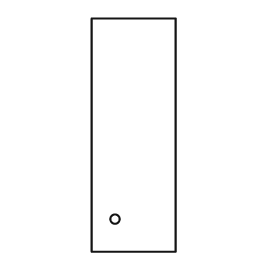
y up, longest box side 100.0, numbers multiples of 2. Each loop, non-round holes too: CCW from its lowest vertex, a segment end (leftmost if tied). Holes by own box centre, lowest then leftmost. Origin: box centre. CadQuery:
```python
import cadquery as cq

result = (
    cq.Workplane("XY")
    .moveTo(-18.0, -50.0)
    .lineTo(18.0, -50.0)
    .lineTo(18.0, 50.0)
    .lineTo(-18.0, 50.0)
    .close()
    .moveTo(-8.0, -36.0)
    .circle(2.0)
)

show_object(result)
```